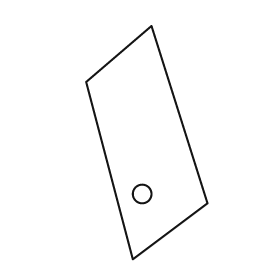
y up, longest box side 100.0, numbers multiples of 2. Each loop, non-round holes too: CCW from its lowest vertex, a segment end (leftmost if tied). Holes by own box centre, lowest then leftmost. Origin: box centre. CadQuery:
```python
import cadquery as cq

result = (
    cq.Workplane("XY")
    .moveTo(-6.0, -50.0)
    .lineTo(26.0, -26.0)
    .lineTo(2.0, 50.0)
    .lineTo(-26.0, 26.0)
    .close()
    .moveTo(-2.0, -22.0)
    .circle(4.0)
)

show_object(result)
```